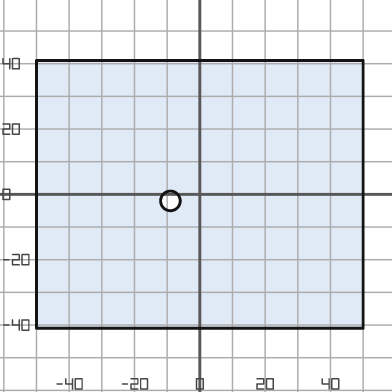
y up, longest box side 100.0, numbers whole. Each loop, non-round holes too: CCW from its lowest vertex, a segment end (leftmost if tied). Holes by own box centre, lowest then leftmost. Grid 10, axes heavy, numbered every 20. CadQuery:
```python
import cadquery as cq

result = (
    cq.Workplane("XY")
    .moveTo(-50.0, -41.0)
    .lineTo(50.0, -41.0)
    .lineTo(50.0, 41.0)
    .lineTo(-50.0, 41.0)
    .close()
    .moveTo(-9.0, -2.0)
    .circle(3.0)
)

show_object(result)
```